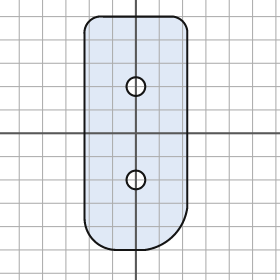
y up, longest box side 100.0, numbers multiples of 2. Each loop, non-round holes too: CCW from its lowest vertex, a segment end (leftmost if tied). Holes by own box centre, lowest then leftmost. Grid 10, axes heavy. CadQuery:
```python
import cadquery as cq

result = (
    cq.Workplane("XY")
    .moveTo(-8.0, -50.0)
    .lineTo(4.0, -50.0)
    .threePointArc((16.0, -44.0), (22.0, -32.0))
    .lineTo(22.0, 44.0)
    .threePointArc((20.0, 48.0), (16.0, 50.0))
    .lineTo(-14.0, 50.0)
    .threePointArc((-20.0, 48.0), (-22.0, 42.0))
    .lineTo(-22.0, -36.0)
    .threePointArc((-18.0, -46.0), (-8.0, -50.0))
    .close()
    .moveTo(0.0, -20.0)
    .circle(4.0)
    .moveTo(0.0, 20.0)
    .circle(4.0)
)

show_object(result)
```